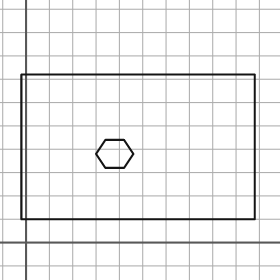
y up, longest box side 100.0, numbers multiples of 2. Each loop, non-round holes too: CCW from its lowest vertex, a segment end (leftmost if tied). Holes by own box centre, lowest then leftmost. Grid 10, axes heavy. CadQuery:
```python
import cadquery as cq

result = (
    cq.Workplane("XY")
    .moveTo(-2.0, 10.0)
    .lineTo(98.0, 10.0)
    .lineTo(98.0, 72.0)
    .lineTo(-2.0, 72.0)
    .close()
    .moveTo(34.0, 32.0)
    .lineTo(42.0, 32.0)
    .lineTo(46.0, 38.0)
    .lineTo(42.0, 44.0)
    .lineTo(34.0, 44.0)
    .lineTo(30.0, 38.0)
    .close()
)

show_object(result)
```